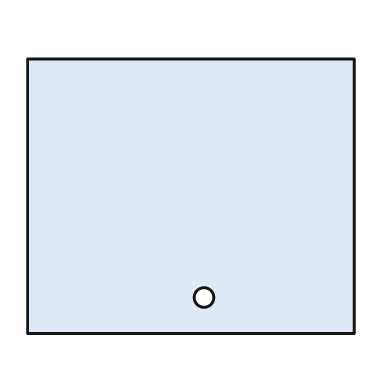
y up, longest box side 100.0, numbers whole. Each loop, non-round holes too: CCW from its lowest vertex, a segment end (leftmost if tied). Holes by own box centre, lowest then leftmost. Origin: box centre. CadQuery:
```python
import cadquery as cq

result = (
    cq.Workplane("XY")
    .moveTo(-50.0, -42.0)
    .lineTo(50.0, -42.0)
    .lineTo(50.0, 42.0)
    .lineTo(-50.0, 42.0)
    .close()
    .moveTo(4.0, -31.0)
    .circle(3.0)
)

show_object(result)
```